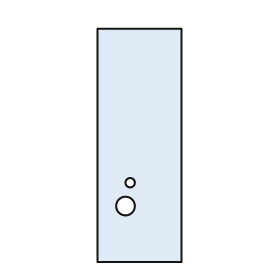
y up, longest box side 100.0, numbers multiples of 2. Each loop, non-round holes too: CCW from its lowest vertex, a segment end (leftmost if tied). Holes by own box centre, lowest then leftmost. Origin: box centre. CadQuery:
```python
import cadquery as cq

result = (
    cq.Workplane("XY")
    .moveTo(-18.0, -50.0)
    .lineTo(18.0, -50.0)
    .lineTo(18.0, 50.0)
    .lineTo(-18.0, 50.0)
    .close()
    .moveTo(-6.0, -26.0)
    .circle(4.0)
    .moveTo(-4.0, -16.0)
    .circle(2.0)
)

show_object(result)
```